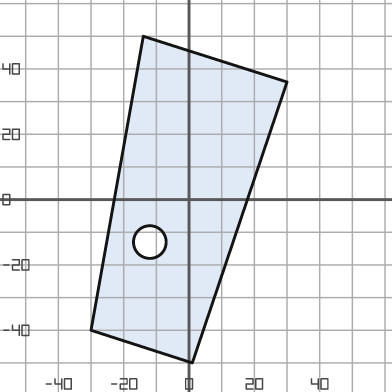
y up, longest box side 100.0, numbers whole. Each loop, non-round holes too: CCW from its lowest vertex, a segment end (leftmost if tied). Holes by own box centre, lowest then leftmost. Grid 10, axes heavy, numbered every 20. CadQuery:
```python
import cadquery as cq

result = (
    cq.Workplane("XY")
    .moveTo(1.0, -50.0)
    .lineTo(30.0, 36.0)
    .lineTo(-14.0, 50.0)
    .lineTo(-30.0, -40.0)
    .close()
    .moveTo(-12.0, -13.0)
    .circle(5.0)
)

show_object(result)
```